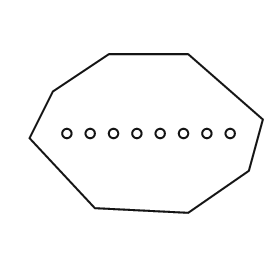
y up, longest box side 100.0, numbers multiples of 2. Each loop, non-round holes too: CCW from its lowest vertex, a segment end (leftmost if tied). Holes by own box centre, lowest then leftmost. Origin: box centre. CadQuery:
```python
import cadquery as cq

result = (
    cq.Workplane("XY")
    .moveTo(18.0, -34.0)
    .lineTo(44.0, -16.0)
    .lineTo(50.0, 6.0)
    .lineTo(18.0, 34.0)
    .lineTo(-16.0, 34.0)
    .lineTo(-40.0, 18.0)
    .lineTo(-50.0, -2.0)
    .lineTo(-22.0, -32.0)
    .close()
    .moveTo(-34.0, 0.0)
    .circle(2.0)
    .moveTo(-24.0, 0.0)
    .circle(2.0)
    .moveTo(-14.0, 0.0)
    .circle(2.0)
    .moveTo(-4.0, 0.0)
    .circle(2.0)
    .moveTo(6.0, 0.0)
    .circle(2.0)
    .moveTo(16.0, 0.0)
    .circle(2.0)
    .moveTo(26.0, 0.0)
    .circle(2.0)
    .moveTo(36.0, 0.0)
    .circle(2.0)
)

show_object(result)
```